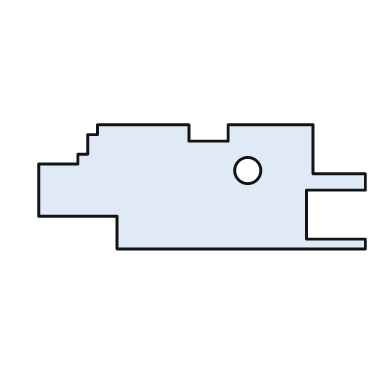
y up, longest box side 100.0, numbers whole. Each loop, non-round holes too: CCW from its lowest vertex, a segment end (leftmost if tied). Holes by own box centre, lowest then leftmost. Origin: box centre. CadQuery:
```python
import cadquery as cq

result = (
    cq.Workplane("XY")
    .moveTo(-26.0, -19.0)
    .lineTo(50.0, -19.0)
    .lineTo(50.0, -16.0)
    .lineTo(32.0, -16.0)
    .lineTo(32.0, -1.0)
    .lineTo(50.0, -1.0)
    .lineTo(50.0, 4.0)
    .lineTo(34.0, 4.0)
    .lineTo(34.0, 19.0)
    .lineTo(8.0, 19.0)
    .lineTo(8.0, 14.0)
    .lineTo(-4.0, 14.0)
    .lineTo(-4.0, 19.0)
    .lineTo(-32.0, 19.0)
    .lineTo(-32.0, 16.0)
    .lineTo(-35.0, 16.0)
    .lineTo(-35.0, 10.0)
    .lineTo(-38.0, 10.0)
    .lineTo(-38.0, 7.0)
    .lineTo(-50.0, 7.0)
    .lineTo(-50.0, -9.0)
    .lineTo(-26.0, -9.0)
    .close()
    .moveTo(14.0, 5.0)
    .circle(4.0)
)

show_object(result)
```